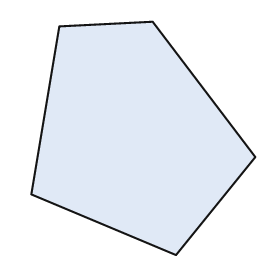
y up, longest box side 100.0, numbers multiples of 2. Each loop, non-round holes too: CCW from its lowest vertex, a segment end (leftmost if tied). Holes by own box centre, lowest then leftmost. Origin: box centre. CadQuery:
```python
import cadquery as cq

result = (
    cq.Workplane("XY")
    .moveTo(14.0, -50.0)
    .lineTo(48.0, -8.0)
    .lineTo(4.0, 50.0)
    .lineTo(-36.0, 48.0)
    .lineTo(-48.0, -24.0)
    .close()
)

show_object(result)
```